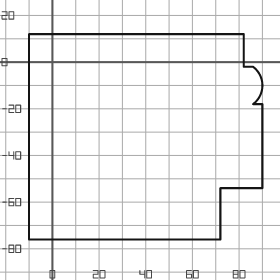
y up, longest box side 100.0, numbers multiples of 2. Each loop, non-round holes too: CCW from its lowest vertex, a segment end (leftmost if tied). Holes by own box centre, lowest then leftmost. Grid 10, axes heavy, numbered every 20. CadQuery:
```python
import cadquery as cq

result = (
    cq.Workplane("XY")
    .moveTo(-10.0, -76.0)
    .lineTo(72.0, -76.0)
    .lineTo(72.0, -54.0)
    .lineTo(90.0, -54.0)
    .lineTo(90.0, -18.0)
    .lineTo(86.0, -18.0)
    .threePointArc((90.0, -10.0), (86.0, -2.0))
    .lineTo(82.0, -2.0)
    .lineTo(82.0, 12.0)
    .lineTo(-10.0, 12.0)
    .close()
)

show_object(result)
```